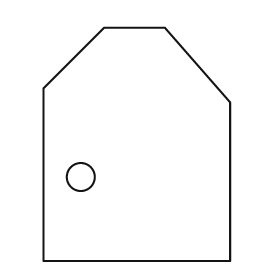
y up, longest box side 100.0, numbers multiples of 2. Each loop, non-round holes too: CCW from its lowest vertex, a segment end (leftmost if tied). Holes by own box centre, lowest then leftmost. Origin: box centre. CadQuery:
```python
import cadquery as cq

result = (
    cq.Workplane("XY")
    .moveTo(-40.0, -50.0)
    .lineTo(40.0, -50.0)
    .lineTo(40.0, 18.0)
    .lineTo(12.0, 50.0)
    .lineTo(-14.0, 50.0)
    .lineTo(-40.0, 24.0)
    .close()
    .moveTo(-24.0, -14.0)
    .circle(6.0)
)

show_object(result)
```